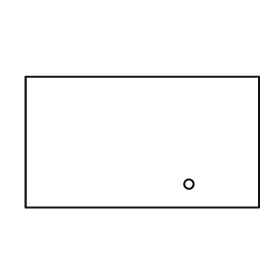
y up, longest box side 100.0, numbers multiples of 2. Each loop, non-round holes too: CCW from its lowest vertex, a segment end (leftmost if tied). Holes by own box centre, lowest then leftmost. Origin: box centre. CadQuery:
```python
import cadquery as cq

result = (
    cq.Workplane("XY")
    .moveTo(-50.0, -28.0)
    .lineTo(50.0, -28.0)
    .lineTo(50.0, 28.0)
    .lineTo(-50.0, 28.0)
    .close()
    .moveTo(20.0, -18.0)
    .circle(2.0)
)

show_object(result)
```